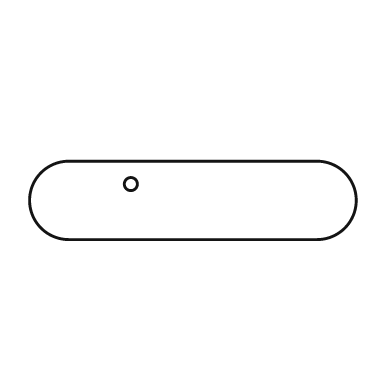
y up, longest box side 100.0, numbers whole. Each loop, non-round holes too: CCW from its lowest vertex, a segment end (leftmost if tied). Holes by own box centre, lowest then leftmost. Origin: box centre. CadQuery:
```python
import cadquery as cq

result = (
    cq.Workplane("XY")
    .moveTo(-38.0, -12.0)
    .lineTo(38.0, -12.0)
    .threePointArc((50.0, 0.0), (38.0, 12.0))
    .lineTo(-38.0, 12.0)
    .threePointArc((-50.0, 0.0), (-38.0, -12.0))
    .close()
    .moveTo(-19.0, 5.0)
    .circle(2.0)
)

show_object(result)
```